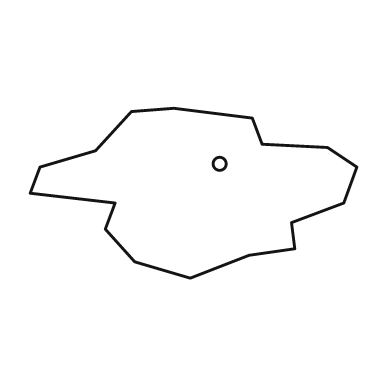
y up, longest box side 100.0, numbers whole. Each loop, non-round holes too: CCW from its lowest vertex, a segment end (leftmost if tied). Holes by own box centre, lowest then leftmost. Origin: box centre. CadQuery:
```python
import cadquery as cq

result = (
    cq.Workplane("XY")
    .moveTo(-1.0, -26.0)
    .lineTo(17.0, -19.0)
    .lineTo(31.0, -17.0)
    .lineTo(30.0, -9.0)
    .lineTo(46.0, -3.0)
    .lineTo(50.0, 8.0)
    .lineTo(41.0, 14.0)
    .lineTo(21.0, 15.0)
    .lineTo(18.0, 23.0)
    .lineTo(-6.0, 26.0)
    .lineTo(-19.0, 25.0)
    .lineTo(-30.0, 13.0)
    .lineTo(-47.0, 8.0)
    .lineTo(-50.0, 0.0)
    .lineTo(-24.0, -3.0)
    .lineTo(-27.0, -11.0)
    .lineTo(-18.0, -21.0)
    .close()
    .moveTo(8.0, 9.0)
    .circle(2.0)
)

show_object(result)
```